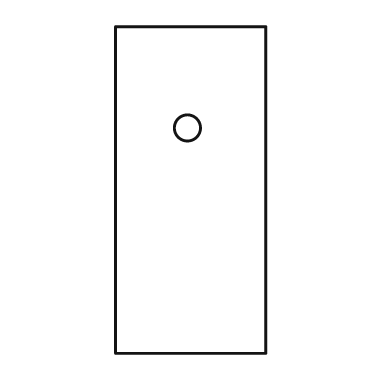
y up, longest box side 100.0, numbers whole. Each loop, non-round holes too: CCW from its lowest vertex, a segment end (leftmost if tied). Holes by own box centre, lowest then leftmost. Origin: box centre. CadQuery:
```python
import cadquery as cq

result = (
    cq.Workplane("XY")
    .moveTo(-23.0, -50.0)
    .lineTo(23.0, -50.0)
    .lineTo(23.0, 50.0)
    .lineTo(-23.0, 50.0)
    .close()
    .moveTo(-1.0, 19.0)
    .circle(4.0)
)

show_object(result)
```